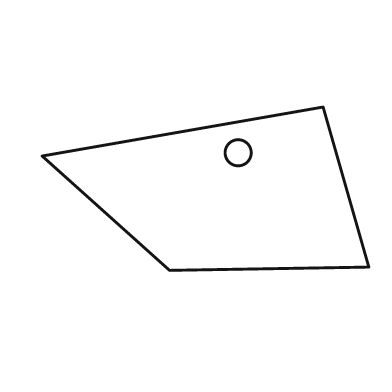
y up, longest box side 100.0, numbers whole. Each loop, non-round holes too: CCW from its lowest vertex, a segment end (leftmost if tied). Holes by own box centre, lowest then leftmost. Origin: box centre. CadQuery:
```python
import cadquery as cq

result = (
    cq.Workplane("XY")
    .moveTo(-11.0, -25.0)
    .lineTo(50.0, -24.0)
    .lineTo(36.0, 25.0)
    .lineTo(-50.0, 10.0)
    .close()
    .moveTo(10.0, 11.0)
    .circle(4.0)
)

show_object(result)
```